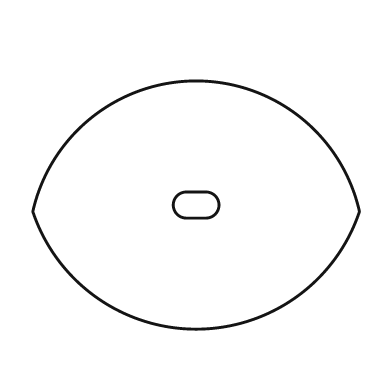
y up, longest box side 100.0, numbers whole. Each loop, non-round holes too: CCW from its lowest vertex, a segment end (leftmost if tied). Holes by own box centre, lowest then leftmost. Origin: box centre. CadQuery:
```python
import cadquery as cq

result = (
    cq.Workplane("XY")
    .moveTo(-50.0, -2.0)
    .threePointArc((0.0, -38.0), (50.0, -2.0))
    .threePointArc((0.0, 38.0), (-50.0, -2.0))
    .close()
    .moveTo(-3.0, -4.0)
    .lineTo(3.0, -4.0)
    .threePointArc((7.0, 0.0), (3.0, 4.0))
    .lineTo(-3.0, 4.0)
    .threePointArc((-7.0, 0.0), (-3.0, -4.0))
    .close()
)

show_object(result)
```